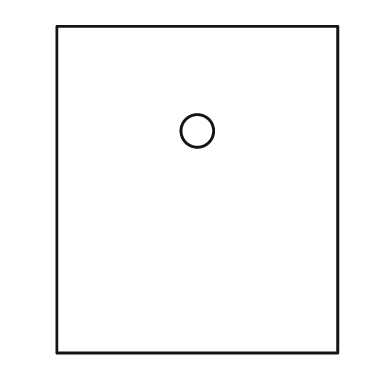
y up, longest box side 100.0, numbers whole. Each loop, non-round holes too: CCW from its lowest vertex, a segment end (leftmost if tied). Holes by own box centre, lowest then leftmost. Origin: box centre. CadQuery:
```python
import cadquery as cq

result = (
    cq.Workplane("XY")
    .moveTo(-43.0, -50.0)
    .lineTo(43.0, -50.0)
    .lineTo(43.0, 50.0)
    .lineTo(-43.0, 50.0)
    .close()
    .moveTo(0.0, 18.0)
    .circle(5.0)
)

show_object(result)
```